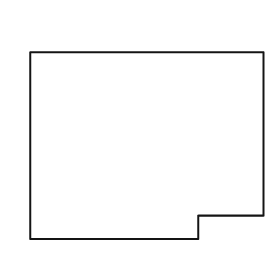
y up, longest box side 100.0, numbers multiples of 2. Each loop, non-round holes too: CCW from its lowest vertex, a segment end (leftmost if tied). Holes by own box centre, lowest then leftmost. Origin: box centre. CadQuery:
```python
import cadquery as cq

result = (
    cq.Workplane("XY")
    .moveTo(-50.0, -40.0)
    .lineTo(22.0, -40.0)
    .lineTo(22.0, -30.0)
    .lineTo(50.0, -30.0)
    .lineTo(50.0, 40.0)
    .lineTo(-50.0, 40.0)
    .close()
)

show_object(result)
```